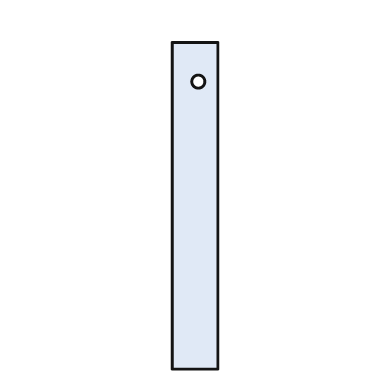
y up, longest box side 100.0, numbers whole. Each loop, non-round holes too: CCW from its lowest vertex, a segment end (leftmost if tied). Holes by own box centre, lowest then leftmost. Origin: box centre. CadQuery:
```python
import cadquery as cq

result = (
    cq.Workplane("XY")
    .moveTo(-7.0, -50.0)
    .lineTo(7.0, -50.0)
    .lineTo(7.0, 50.0)
    .lineTo(-7.0, 50.0)
    .close()
    .moveTo(1.0, 38.0)
    .circle(2.0)
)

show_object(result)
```